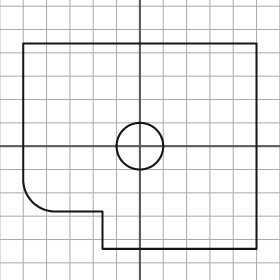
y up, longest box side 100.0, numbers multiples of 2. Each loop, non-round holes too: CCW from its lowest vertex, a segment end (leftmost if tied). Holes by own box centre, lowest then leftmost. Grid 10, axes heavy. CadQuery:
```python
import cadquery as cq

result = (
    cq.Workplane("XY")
    .moveTo(-16.0, -44.0)
    .lineTo(50.0, -44.0)
    .lineTo(50.0, 44.0)
    .lineTo(-50.0, 44.0)
    .lineTo(-50.0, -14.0)
    .threePointArc((-46.0, -24.0), (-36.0, -28.0))
    .lineTo(-16.0, -28.0)
    .close()
    .moveTo(0.0, 0.0)
    .circle(10.0)
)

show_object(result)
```